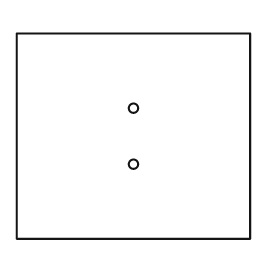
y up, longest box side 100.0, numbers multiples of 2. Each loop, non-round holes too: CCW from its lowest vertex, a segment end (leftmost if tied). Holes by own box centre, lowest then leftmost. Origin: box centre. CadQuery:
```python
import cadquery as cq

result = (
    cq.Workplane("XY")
    .moveTo(-50.0, -44.0)
    .lineTo(50.0, -44.0)
    .lineTo(50.0, 44.0)
    .lineTo(-50.0, 44.0)
    .close()
    .moveTo(0.0, -12.0)
    .circle(2.0)
    .moveTo(0.0, 12.0)
    .circle(2.0)
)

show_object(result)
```